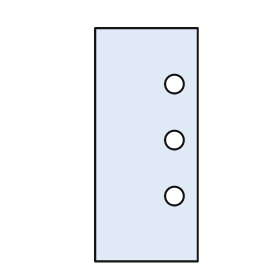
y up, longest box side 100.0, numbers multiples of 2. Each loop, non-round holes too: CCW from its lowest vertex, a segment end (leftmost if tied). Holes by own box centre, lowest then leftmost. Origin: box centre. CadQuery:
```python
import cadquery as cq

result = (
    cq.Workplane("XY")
    .moveTo(-22.0, -50.0)
    .lineTo(22.0, -50.0)
    .lineTo(22.0, 50.0)
    .lineTo(-22.0, 50.0)
    .close()
    .moveTo(12.0, -22.0)
    .circle(4.0)
    .moveTo(12.0, 2.0)
    .circle(4.0)
    .moveTo(12.0, 26.0)
    .circle(4.0)
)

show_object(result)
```